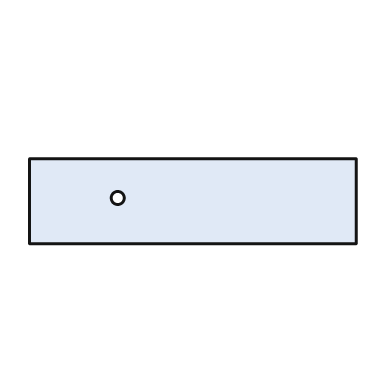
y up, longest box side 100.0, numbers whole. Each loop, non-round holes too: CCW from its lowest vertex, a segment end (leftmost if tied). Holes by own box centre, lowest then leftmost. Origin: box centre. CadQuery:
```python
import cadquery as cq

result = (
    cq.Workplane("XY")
    .moveTo(-50.0, -13.0)
    .lineTo(50.0, -13.0)
    .lineTo(50.0, 13.0)
    .lineTo(-50.0, 13.0)
    .close()
    .moveTo(-23.0, 1.0)
    .circle(2.0)
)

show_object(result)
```